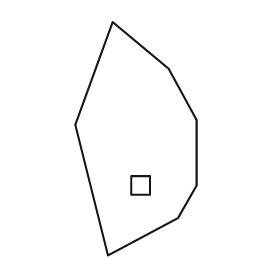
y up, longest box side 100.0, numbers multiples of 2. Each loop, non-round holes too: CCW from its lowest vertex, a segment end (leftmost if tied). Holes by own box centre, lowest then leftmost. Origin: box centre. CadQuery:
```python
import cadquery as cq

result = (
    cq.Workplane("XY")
    .moveTo(-12.0, -50.0)
    .lineTo(18.0, -34.0)
    .lineTo(26.0, -20.0)
    .lineTo(26.0, 8.0)
    .lineTo(14.0, 30.0)
    .lineTo(-10.0, 50.0)
    .lineTo(-26.0, 6.0)
    .close()
    .moveTo(-2.0, -24.0)
    .lineTo(6.0, -24.0)
    .lineTo(6.0, -16.0)
    .lineTo(-2.0, -16.0)
    .close()
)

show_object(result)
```